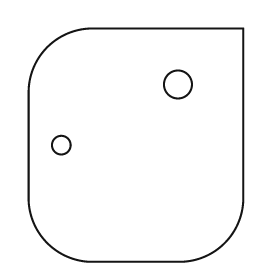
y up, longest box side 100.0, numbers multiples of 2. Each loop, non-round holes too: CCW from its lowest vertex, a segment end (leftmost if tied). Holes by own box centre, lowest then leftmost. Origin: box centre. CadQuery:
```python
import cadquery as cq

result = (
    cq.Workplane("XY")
    .moveTo(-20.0, -50.0)
    .lineTo(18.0, -50.0)
    .threePointArc((38.0, -42.0), (46.0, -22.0))
    .lineTo(46.0, 50.0)
    .lineTo(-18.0, 50.0)
    .threePointArc((-38.0, 42.0), (-46.0, 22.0))
    .lineTo(-46.0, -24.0)
    .threePointArc((-38.0, -42.0), (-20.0, -50.0))
    .close()
    .moveTo(-32.0, 0.0)
    .circle(4.0)
    .moveTo(18.0, 26.0)
    .circle(6.0)
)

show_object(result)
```